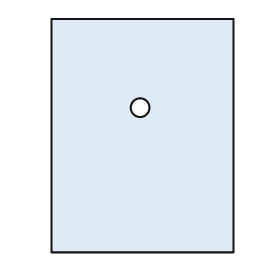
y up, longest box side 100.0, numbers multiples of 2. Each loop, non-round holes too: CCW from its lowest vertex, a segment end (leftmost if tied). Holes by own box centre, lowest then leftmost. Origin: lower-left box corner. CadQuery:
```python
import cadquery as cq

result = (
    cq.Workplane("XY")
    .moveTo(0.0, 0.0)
    .lineTo(78.0, 0.0)
    .lineTo(78.0, 100.0)
    .lineTo(0.0, 100.0)
    .close()
    .moveTo(38.0, 62.0)
    .circle(4.0)
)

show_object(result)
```